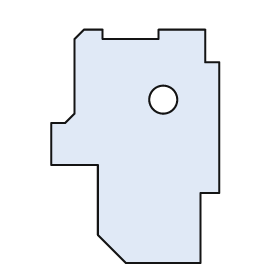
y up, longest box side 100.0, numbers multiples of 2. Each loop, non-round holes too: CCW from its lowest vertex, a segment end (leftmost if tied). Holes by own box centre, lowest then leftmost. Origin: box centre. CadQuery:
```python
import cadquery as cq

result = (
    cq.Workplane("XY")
    .moveTo(-4.0, -50.0)
    .lineTo(28.0, -50.0)
    .lineTo(28.0, -20.0)
    .lineTo(36.0, -20.0)
    .lineTo(36.0, 36.0)
    .lineTo(30.0, 36.0)
    .lineTo(30.0, 50.0)
    .lineTo(10.0, 50.0)
    .lineTo(10.0, 46.0)
    .lineTo(-14.0, 46.0)
    .lineTo(-14.0, 50.0)
    .lineTo(-22.0, 50.0)
    .lineTo(-26.0, 46.0)
    .lineTo(-26.0, 14.0)
    .lineTo(-30.0, 10.0)
    .lineTo(-36.0, 10.0)
    .lineTo(-36.0, -8.0)
    .lineTo(-16.0, -8.0)
    .lineTo(-16.0, -38.0)
    .close()
    .moveTo(12.0, 20.0)
    .circle(6.0)
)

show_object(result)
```